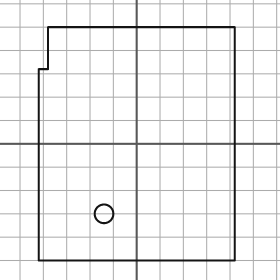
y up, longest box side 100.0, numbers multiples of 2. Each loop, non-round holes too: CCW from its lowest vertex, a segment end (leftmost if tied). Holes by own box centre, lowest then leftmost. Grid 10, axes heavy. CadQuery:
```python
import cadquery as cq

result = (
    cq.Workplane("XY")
    .moveTo(-42.0, -50.0)
    .lineTo(42.0, -50.0)
    .lineTo(42.0, 50.0)
    .lineTo(-38.0, 50.0)
    .lineTo(-38.0, 32.0)
    .lineTo(-42.0, 32.0)
    .close()
    .moveTo(-14.0, -30.0)
    .circle(4.0)
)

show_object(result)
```